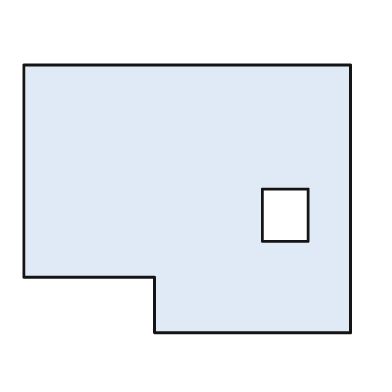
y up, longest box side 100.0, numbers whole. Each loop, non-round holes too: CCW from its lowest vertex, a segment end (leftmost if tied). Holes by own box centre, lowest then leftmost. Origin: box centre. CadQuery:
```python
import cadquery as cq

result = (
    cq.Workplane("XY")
    .moveTo(-10.0, -41.0)
    .lineTo(50.0, -41.0)
    .lineTo(50.0, 41.0)
    .lineTo(-50.0, 41.0)
    .lineTo(-50.0, -24.0)
    .lineTo(-10.0, -24.0)
    .close()
    .moveTo(23.0, -13.0)
    .lineTo(37.0, -13.0)
    .lineTo(37.0, 3.0)
    .lineTo(23.0, 3.0)
    .close()
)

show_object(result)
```